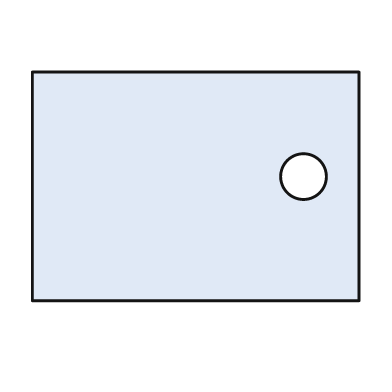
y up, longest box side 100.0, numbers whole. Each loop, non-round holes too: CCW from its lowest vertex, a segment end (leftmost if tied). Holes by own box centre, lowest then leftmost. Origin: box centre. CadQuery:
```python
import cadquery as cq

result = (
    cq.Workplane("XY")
    .moveTo(-50.0, -35.0)
    .lineTo(50.0, -35.0)
    .lineTo(50.0, 35.0)
    .lineTo(-50.0, 35.0)
    .close()
    .moveTo(33.0, 3.0)
    .circle(7.0)
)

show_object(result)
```